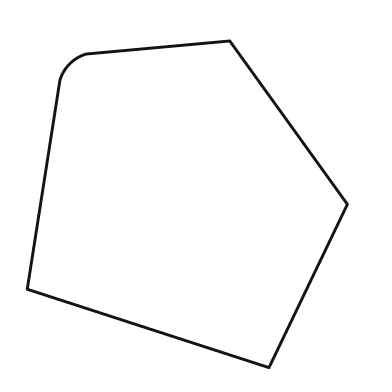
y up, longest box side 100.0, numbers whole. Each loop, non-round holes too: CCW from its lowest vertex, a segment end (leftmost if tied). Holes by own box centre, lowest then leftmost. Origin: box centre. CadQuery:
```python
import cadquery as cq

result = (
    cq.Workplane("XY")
    .moveTo(25.0, -50.0)
    .lineTo(49.0, 0.0)
    .lineTo(13.0, 50.0)
    .lineTo(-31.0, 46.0)
    .threePointArc((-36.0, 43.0), (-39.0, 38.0))
    .lineTo(-49.0, -26.0)
    .close()
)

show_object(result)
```